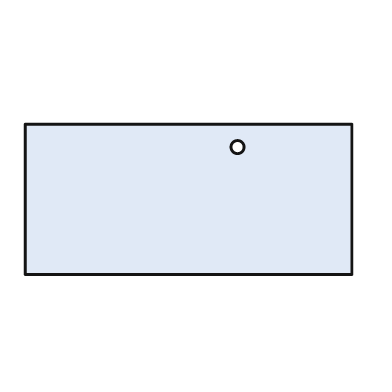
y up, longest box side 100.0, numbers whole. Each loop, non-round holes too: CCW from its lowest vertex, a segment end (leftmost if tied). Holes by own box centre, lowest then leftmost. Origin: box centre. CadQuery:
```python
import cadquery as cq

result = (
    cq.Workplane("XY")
    .moveTo(-50.0, -23.0)
    .lineTo(50.0, -23.0)
    .lineTo(50.0, 23.0)
    .lineTo(-50.0, 23.0)
    .close()
    .moveTo(15.0, 16.0)
    .circle(2.0)
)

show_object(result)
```